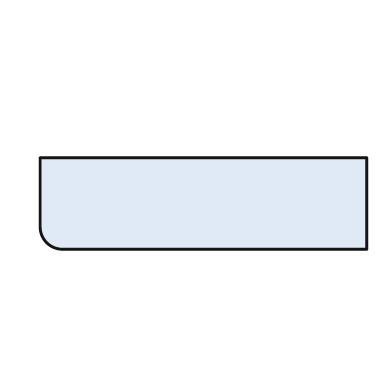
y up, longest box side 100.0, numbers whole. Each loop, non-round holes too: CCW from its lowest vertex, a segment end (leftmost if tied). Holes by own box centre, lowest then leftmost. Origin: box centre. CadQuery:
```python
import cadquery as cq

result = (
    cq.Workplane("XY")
    .moveTo(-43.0, -14.0)
    .lineTo(50.0, -14.0)
    .lineTo(50.0, 14.0)
    .lineTo(-50.0, 14.0)
    .lineTo(-50.0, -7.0)
    .threePointArc((-48.0, -12.0), (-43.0, -14.0))
    .close()
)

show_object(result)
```